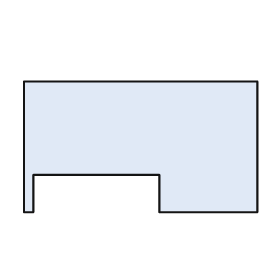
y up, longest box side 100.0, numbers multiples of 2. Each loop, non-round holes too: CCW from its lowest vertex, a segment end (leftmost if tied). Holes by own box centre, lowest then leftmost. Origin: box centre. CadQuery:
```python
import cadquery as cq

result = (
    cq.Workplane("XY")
    .moveTo(-50.0, -28.0)
    .lineTo(-46.0, -28.0)
    .lineTo(-46.0, -12.0)
    .lineTo(8.0, -12.0)
    .lineTo(8.0, -28.0)
    .lineTo(50.0, -28.0)
    .lineTo(50.0, 28.0)
    .lineTo(-50.0, 28.0)
    .close()
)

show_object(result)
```